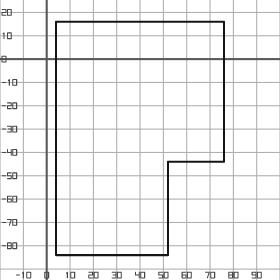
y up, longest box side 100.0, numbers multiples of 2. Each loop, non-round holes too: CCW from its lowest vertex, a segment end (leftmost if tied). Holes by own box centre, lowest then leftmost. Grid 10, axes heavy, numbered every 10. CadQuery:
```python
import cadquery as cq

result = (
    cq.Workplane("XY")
    .moveTo(4.0, -84.0)
    .lineTo(52.0, -84.0)
    .lineTo(52.0, -44.0)
    .lineTo(76.0, -44.0)
    .lineTo(76.0, 16.0)
    .lineTo(4.0, 16.0)
    .close()
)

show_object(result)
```